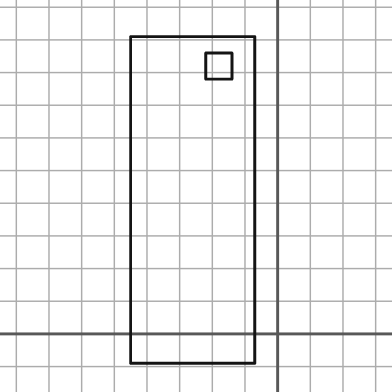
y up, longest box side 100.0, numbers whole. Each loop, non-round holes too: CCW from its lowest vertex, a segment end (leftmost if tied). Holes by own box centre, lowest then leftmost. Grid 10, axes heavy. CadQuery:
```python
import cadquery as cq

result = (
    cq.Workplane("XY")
    .moveTo(-45.0, -9.0)
    .lineTo(-7.0, -9.0)
    .lineTo(-7.0, 91.0)
    .lineTo(-45.0, 91.0)
    .close()
    .moveTo(-22.0, 78.0)
    .lineTo(-14.0, 78.0)
    .lineTo(-14.0, 86.0)
    .lineTo(-22.0, 86.0)
    .close()
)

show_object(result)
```